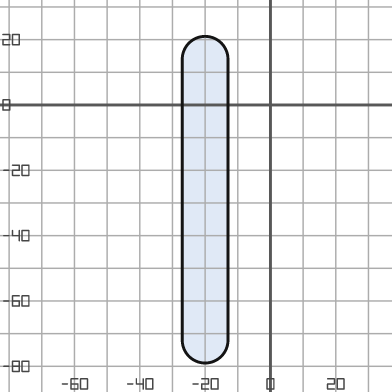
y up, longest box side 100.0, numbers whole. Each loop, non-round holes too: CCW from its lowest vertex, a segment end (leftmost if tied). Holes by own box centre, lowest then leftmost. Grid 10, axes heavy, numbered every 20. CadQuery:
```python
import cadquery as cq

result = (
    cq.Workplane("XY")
    .moveTo(-27.0, -72.0)
    .threePointArc((-20.0, -79.0), (-13.0, -72.0))
    .lineTo(-13.0, 14.0)
    .threePointArc((-20.0, 21.0), (-27.0, 14.0))
    .close()
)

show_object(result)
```